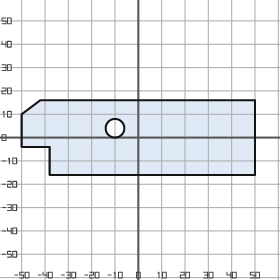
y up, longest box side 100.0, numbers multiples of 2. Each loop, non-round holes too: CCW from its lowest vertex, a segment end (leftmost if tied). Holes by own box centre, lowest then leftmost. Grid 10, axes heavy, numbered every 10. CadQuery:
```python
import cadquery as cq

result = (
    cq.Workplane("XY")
    .moveTo(-38.0, -16.0)
    .lineTo(50.0, -16.0)
    .lineTo(50.0, 16.0)
    .lineTo(-42.0, 16.0)
    .lineTo(-50.0, 10.0)
    .lineTo(-50.0, -4.0)
    .lineTo(-38.0, -4.0)
    .close()
    .moveTo(-10.0, 4.0)
    .circle(4.0)
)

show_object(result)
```